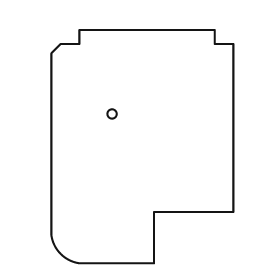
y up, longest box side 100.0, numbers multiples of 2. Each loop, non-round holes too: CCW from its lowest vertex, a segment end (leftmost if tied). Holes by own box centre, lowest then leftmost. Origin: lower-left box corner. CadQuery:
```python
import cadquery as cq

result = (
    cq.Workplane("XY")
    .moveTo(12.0, 0.0)
    .lineTo(44.0, 0.0)
    .lineTo(44.0, 22.0)
    .lineTo(78.0, 22.0)
    .lineTo(78.0, 94.0)
    .lineTo(70.0, 94.0)
    .lineTo(70.0, 100.0)
    .lineTo(12.0, 100.0)
    .lineTo(12.0, 94.0)
    .lineTo(4.0, 94.0)
    .lineTo(0.0, 90.0)
    .lineTo(0.0, 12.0)
    .threePointArc((4.0, 4.0), (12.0, 0.0))
    .close()
    .moveTo(26.0, 64.0)
    .circle(2.0)
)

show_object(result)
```